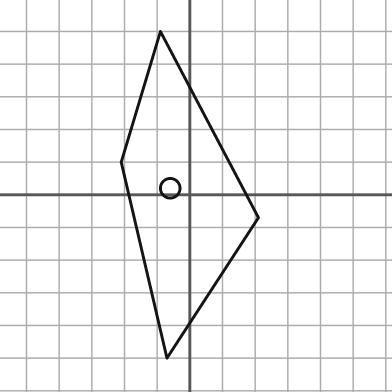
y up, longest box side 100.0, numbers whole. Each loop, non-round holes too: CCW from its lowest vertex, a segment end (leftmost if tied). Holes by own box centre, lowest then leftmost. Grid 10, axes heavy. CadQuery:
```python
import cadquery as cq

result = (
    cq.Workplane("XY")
    .moveTo(-7.0, -50.0)
    .lineTo(21.0, -7.0)
    .lineTo(-9.0, 50.0)
    .lineTo(-21.0, 10.0)
    .close()
    .moveTo(-6.0, 2.0)
    .circle(3.0)
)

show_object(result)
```